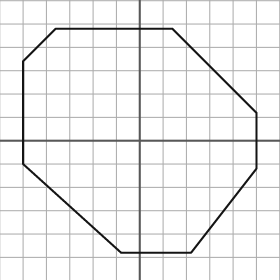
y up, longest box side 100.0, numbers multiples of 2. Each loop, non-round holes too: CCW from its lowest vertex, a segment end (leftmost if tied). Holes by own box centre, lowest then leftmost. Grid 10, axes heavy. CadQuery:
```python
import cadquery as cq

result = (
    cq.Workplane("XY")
    .moveTo(-8.0, -48.0)
    .lineTo(22.0, -48.0)
    .lineTo(50.0, -12.0)
    .lineTo(50.0, 12.0)
    .lineTo(14.0, 48.0)
    .lineTo(-36.0, 48.0)
    .lineTo(-50.0, 34.0)
    .lineTo(-50.0, -10.0)
    .close()
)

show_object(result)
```